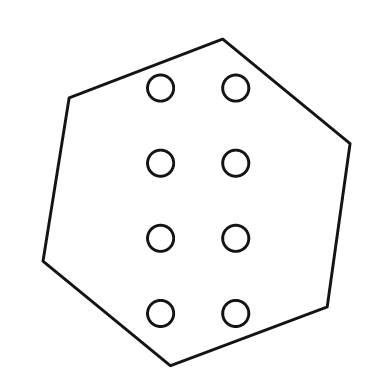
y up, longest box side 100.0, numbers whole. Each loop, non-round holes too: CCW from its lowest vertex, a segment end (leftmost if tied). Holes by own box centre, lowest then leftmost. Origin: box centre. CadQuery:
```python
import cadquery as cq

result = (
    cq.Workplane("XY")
    .moveTo(-8.0, -50.0)
    .lineTo(40.0, -32.0)
    .lineTo(47.0, 18.0)
    .lineTo(8.0, 50.0)
    .lineTo(-39.0, 32.0)
    .lineTo(-47.0, -18.0)
    .close()
    .moveTo(-11.0, -34.0)
    .circle(4.0)
    .moveTo(12.0, -34.0)
    .circle(4.0)
    .moveTo(-11.0, -11.0)
    .circle(4.0)
    .moveTo(12.0, -11.0)
    .circle(4.0)
    .moveTo(-11.0, 12.0)
    .circle(4.0)
    .moveTo(12.0, 12.0)
    .circle(4.0)
    .moveTo(-11.0, 35.0)
    .circle(4.0)
    .moveTo(12.0, 35.0)
    .circle(4.0)
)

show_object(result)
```